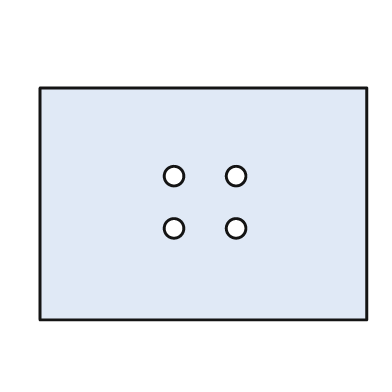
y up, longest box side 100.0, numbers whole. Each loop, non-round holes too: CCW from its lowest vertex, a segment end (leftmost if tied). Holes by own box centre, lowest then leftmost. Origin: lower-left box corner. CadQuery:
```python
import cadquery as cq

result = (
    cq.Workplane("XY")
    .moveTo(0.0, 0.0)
    .lineTo(100.0, 0.0)
    .lineTo(100.0, 71.0)
    .lineTo(0.0, 71.0)
    .close()
    .moveTo(41.0, 28.0)
    .circle(3.0)
    .moveTo(60.0, 28.0)
    .circle(3.0)
    .moveTo(41.0, 44.0)
    .circle(3.0)
    .moveTo(60.0, 44.0)
    .circle(3.0)
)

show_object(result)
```